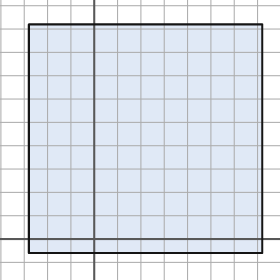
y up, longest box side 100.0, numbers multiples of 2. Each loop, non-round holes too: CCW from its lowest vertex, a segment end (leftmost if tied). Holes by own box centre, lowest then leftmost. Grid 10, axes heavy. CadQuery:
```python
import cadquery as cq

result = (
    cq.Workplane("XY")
    .moveTo(-28.0, -6.0)
    .lineTo(72.0, -6.0)
    .lineTo(72.0, 92.0)
    .lineTo(-28.0, 92.0)
    .close()
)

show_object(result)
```